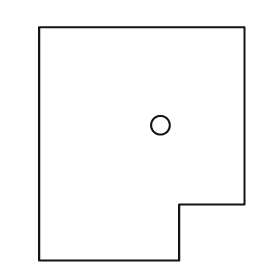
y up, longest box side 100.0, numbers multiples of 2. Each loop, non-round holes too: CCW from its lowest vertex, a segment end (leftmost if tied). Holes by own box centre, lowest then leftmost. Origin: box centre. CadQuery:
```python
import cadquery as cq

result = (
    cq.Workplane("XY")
    .moveTo(-44.0, -50.0)
    .lineTo(16.0, -50.0)
    .lineTo(16.0, -26.0)
    .lineTo(44.0, -26.0)
    .lineTo(44.0, 50.0)
    .lineTo(-44.0, 50.0)
    .close()
    .moveTo(8.0, 8.0)
    .circle(4.0)
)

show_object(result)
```